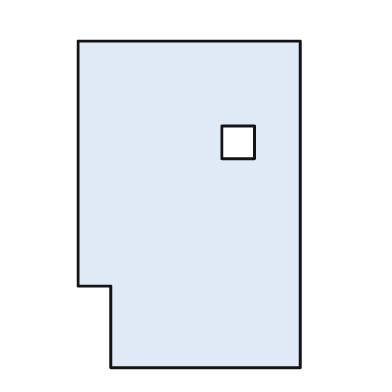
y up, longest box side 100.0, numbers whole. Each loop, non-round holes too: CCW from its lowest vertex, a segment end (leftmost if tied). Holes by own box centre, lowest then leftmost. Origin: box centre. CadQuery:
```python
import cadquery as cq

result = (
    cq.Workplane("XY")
    .moveTo(-24.0, -50.0)
    .lineTo(34.0, -50.0)
    .lineTo(34.0, 50.0)
    .lineTo(-34.0, 50.0)
    .lineTo(-34.0, -25.0)
    .lineTo(-24.0, -25.0)
    .close()
    .moveTo(10.0, 14.0)
    .lineTo(20.0, 14.0)
    .lineTo(20.0, 24.0)
    .lineTo(10.0, 24.0)
    .close()
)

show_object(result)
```